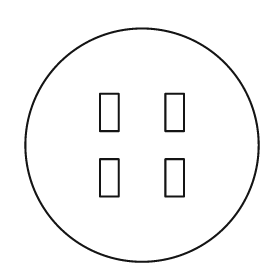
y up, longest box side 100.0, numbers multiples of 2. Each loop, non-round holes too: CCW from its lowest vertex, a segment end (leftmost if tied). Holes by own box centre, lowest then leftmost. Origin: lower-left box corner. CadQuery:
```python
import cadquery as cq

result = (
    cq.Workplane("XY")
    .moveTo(50.0, 50.0)
    .circle(50.0)
    .moveTo(32.0, 28.0)
    .lineTo(40.0, 28.0)
    .lineTo(40.0, 44.0)
    .lineTo(32.0, 44.0)
    .close()
    .moveTo(60.0, 28.0)
    .lineTo(68.0, 28.0)
    .lineTo(68.0, 44.0)
    .lineTo(60.0, 44.0)
    .close()
    .moveTo(32.0, 56.0)
    .lineTo(40.0, 56.0)
    .lineTo(40.0, 72.0)
    .lineTo(32.0, 72.0)
    .close()
    .moveTo(60.0, 56.0)
    .lineTo(68.0, 56.0)
    .lineTo(68.0, 72.0)
    .lineTo(60.0, 72.0)
    .close()
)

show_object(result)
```